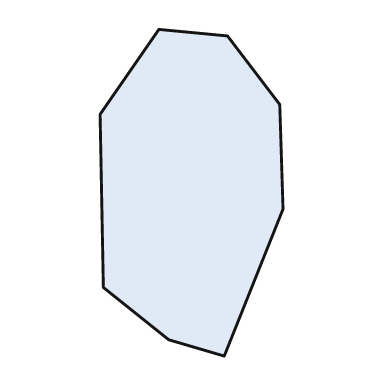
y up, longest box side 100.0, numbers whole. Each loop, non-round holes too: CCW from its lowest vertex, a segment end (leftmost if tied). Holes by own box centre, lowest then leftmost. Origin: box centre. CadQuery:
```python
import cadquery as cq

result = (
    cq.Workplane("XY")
    .moveTo(10.0, -50.0)
    .lineTo(28.0, -5.0)
    .lineTo(27.0, 27.0)
    .lineTo(11.0, 48.0)
    .lineTo(-10.0, 50.0)
    .lineTo(-28.0, 24.0)
    .lineTo(-27.0, -29.0)
    .lineTo(-7.0, -45.0)
    .close()
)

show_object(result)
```